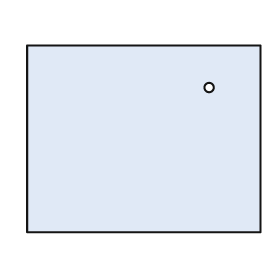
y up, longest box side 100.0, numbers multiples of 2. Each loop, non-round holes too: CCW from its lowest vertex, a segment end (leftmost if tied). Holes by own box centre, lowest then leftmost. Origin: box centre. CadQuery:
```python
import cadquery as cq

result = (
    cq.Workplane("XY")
    .moveTo(-50.0, -40.0)
    .lineTo(50.0, -40.0)
    .lineTo(50.0, 40.0)
    .lineTo(-50.0, 40.0)
    .close()
    .moveTo(28.0, 22.0)
    .circle(2.0)
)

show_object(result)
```